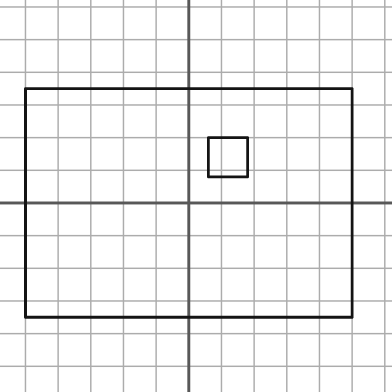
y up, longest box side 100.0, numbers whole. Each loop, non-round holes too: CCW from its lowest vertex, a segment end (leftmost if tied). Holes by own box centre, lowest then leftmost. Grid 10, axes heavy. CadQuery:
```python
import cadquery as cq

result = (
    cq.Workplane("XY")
    .moveTo(-50.0, -35.0)
    .lineTo(50.0, -35.0)
    .lineTo(50.0, 35.0)
    .lineTo(-50.0, 35.0)
    .close()
    .moveTo(6.0, 8.0)
    .lineTo(18.0, 8.0)
    .lineTo(18.0, 20.0)
    .lineTo(6.0, 20.0)
    .close()
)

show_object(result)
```